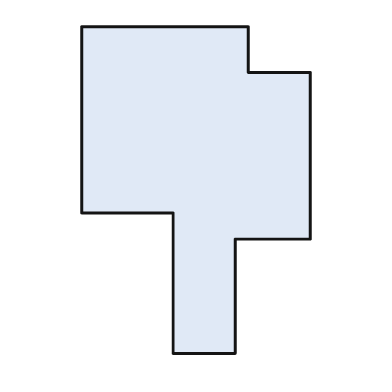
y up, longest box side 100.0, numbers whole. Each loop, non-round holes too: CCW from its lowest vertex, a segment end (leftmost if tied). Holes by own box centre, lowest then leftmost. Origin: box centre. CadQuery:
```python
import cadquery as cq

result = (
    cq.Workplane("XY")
    .moveTo(-7.0, -50.0)
    .lineTo(12.0, -50.0)
    .lineTo(12.0, -15.0)
    .lineTo(35.0, -15.0)
    .lineTo(35.0, 36.0)
    .lineTo(16.0, 36.0)
    .lineTo(16.0, 50.0)
    .lineTo(-35.0, 50.0)
    .lineTo(-35.0, -7.0)
    .lineTo(-7.0, -7.0)
    .close()
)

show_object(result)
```